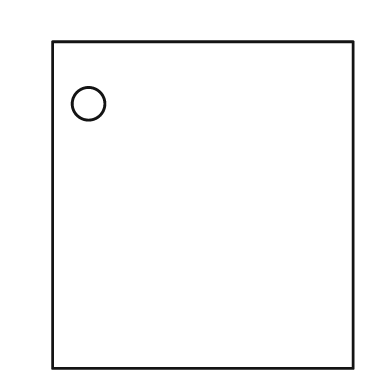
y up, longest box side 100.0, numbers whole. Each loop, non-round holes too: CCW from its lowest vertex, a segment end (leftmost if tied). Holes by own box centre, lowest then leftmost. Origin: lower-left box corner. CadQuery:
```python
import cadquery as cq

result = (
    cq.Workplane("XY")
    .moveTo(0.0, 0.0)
    .lineTo(92.0, 0.0)
    .lineTo(92.0, 100.0)
    .lineTo(0.0, 100.0)
    .close()
    .moveTo(11.0, 81.0)
    .circle(5.0)
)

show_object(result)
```